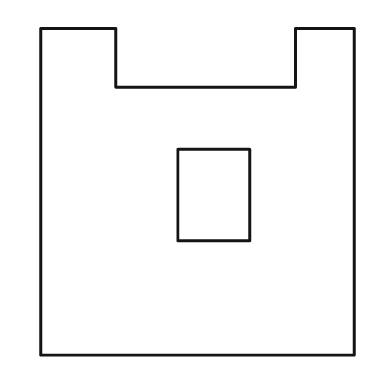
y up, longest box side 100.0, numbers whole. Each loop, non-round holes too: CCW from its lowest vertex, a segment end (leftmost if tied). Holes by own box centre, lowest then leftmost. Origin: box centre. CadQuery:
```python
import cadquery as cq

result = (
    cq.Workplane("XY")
    .moveTo(-48.0, -50.0)
    .lineTo(48.0, -50.0)
    .lineTo(48.0, 50.0)
    .lineTo(30.0, 50.0)
    .lineTo(30.0, 32.0)
    .lineTo(-25.0, 32.0)
    .lineTo(-25.0, 50.0)
    .lineTo(-48.0, 50.0)
    .close()
    .moveTo(-6.0, -15.0)
    .lineTo(16.0, -15.0)
    .lineTo(16.0, 13.0)
    .lineTo(-6.0, 13.0)
    .close()
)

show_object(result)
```